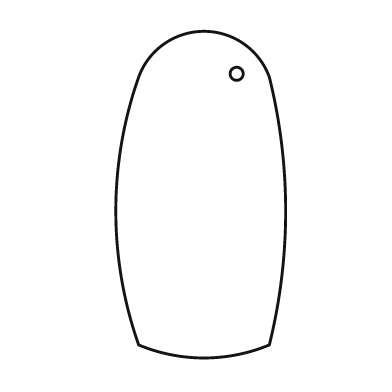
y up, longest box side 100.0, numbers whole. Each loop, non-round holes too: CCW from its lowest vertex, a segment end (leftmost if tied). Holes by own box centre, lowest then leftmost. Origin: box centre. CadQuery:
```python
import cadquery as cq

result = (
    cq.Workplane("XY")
    .moveTo(-19.0, -46.0)
    .threePointArc((1.0, -50.0), (21.0, -46.0))
    .threePointArc((26.0, -5.0), (21.0, 36.0))
    .threePointArc((1.0, 50.0), (-19.0, 36.0))
    .threePointArc((-26.0, -5.0), (-19.0, -46.0))
    .close()
    .moveTo(11.0, 37.0)
    .circle(2.0)
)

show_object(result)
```